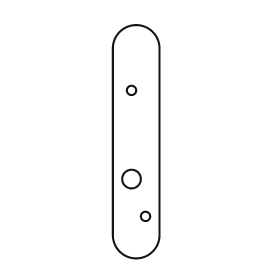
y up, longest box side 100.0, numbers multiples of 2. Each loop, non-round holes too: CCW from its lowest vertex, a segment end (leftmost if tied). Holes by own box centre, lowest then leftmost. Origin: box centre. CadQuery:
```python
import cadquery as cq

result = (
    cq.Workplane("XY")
    .moveTo(-10.0, -40.0)
    .threePointArc((0.0, -50.0), (10.0, -40.0))
    .lineTo(10.0, 40.0)
    .threePointArc((0.0, 50.0), (-10.0, 40.0))
    .close()
    .moveTo(4.0, -32.0)
    .circle(2.0)
    .moveTo(-2.0, -16.0)
    .circle(4.0)
    .moveTo(-2.0, 22.0)
    .circle(2.0)
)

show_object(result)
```